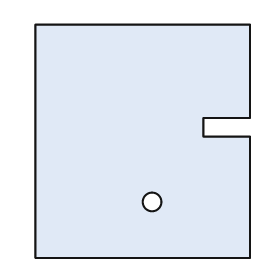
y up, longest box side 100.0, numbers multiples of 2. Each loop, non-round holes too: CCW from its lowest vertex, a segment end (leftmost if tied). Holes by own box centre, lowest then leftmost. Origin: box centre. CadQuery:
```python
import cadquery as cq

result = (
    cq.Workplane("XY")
    .moveTo(-46.0, -50.0)
    .lineTo(46.0, -50.0)
    .lineTo(46.0, 2.0)
    .lineTo(26.0, 2.0)
    .lineTo(26.0, 10.0)
    .lineTo(46.0, 10.0)
    .lineTo(46.0, 50.0)
    .lineTo(-46.0, 50.0)
    .close()
    .moveTo(4.0, -26.0)
    .circle(4.0)
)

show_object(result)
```